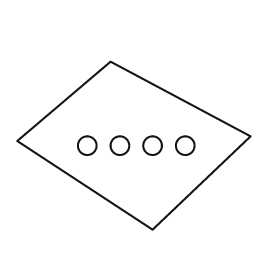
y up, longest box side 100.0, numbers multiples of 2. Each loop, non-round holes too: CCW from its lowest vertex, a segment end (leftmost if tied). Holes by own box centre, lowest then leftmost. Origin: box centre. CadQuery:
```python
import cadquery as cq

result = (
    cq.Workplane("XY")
    .moveTo(8.0, -36.0)
    .lineTo(50.0, 4.0)
    .lineTo(-10.0, 36.0)
    .lineTo(-50.0, 2.0)
    .close()
    .moveTo(-20.0, 0.0)
    .circle(4.0)
    .moveTo(-6.0, 0.0)
    .circle(4.0)
    .moveTo(8.0, 0.0)
    .circle(4.0)
    .moveTo(22.0, 0.0)
    .circle(4.0)
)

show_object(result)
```